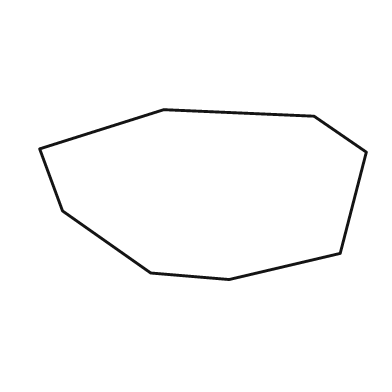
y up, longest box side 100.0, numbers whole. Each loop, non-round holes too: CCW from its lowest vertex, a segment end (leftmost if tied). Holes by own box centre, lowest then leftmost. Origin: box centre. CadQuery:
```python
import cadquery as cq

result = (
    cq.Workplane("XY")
    .moveTo(8.0, -26.0)
    .lineTo(42.0, -18.0)
    .lineTo(50.0, 13.0)
    .lineTo(34.0, 24.0)
    .lineTo(-12.0, 26.0)
    .lineTo(-50.0, 14.0)
    .lineTo(-43.0, -5.0)
    .lineTo(-16.0, -24.0)
    .close()
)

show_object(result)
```